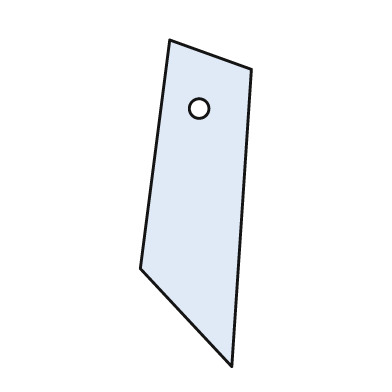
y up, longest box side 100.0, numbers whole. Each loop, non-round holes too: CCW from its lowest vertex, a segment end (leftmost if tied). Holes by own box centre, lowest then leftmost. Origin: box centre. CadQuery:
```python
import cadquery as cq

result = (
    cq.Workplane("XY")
    .moveTo(11.0, -50.0)
    .lineTo(17.0, 41.0)
    .lineTo(-8.0, 50.0)
    .lineTo(-17.0, -20.0)
    .close()
    .moveTo(1.0, 29.0)
    .circle(3.0)
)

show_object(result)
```